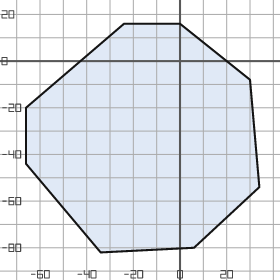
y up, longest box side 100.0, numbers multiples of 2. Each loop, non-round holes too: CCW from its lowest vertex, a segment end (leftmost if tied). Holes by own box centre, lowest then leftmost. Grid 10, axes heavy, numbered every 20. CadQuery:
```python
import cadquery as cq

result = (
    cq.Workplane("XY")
    .moveTo(-34.0, -82.0)
    .lineTo(6.0, -80.0)
    .lineTo(34.0, -54.0)
    .lineTo(30.0, -8.0)
    .lineTo(0.0, 16.0)
    .lineTo(-24.0, 16.0)
    .lineTo(-66.0, -20.0)
    .lineTo(-66.0, -44.0)
    .close()
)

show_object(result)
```